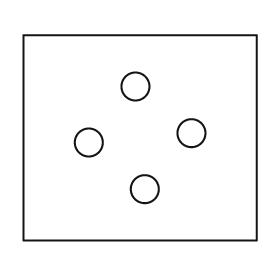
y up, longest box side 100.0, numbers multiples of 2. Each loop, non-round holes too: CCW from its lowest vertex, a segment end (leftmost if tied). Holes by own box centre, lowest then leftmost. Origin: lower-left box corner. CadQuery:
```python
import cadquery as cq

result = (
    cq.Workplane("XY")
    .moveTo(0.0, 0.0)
    .lineTo(100.0, 0.0)
    .lineTo(100.0, 88.0)
    .lineTo(0.0, 88.0)
    .close()
    .moveTo(52.0, 22.0)
    .circle(6.0)
    .moveTo(28.0, 42.0)
    .circle(6.0)
    .moveTo(72.0, 46.0)
    .circle(6.0)
    .moveTo(48.0, 66.0)
    .circle(6.0)
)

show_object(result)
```